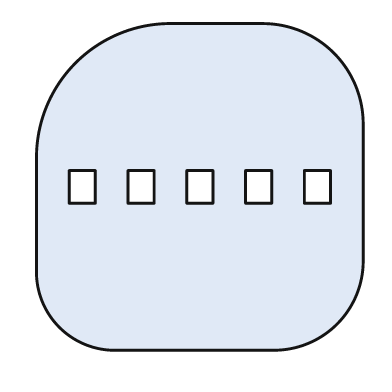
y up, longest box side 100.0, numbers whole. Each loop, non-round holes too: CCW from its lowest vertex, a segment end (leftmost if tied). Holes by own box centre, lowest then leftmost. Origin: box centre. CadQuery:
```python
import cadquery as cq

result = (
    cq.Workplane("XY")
    .moveTo(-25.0, -50.0)
    .lineTo(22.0, -50.0)
    .threePointArc((42.0, -42.0), (50.0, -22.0))
    .lineTo(50.0, 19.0)
    .threePointArc((41.0, 41.0), (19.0, 50.0))
    .lineTo(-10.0, 50.0)
    .threePointArc((-38.0, 38.0), (-50.0, 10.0))
    .lineTo(-50.0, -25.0)
    .threePointArc((-43.0, -43.0), (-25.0, -50.0))
    .close()
    .moveTo(-40.0, -5.0)
    .lineTo(-32.0, -5.0)
    .lineTo(-32.0, 5.0)
    .lineTo(-40.0, 5.0)
    .close()
    .moveTo(-22.0, -5.0)
    .lineTo(-14.0, -5.0)
    .lineTo(-14.0, 5.0)
    .lineTo(-22.0, 5.0)
    .close()
    .moveTo(-4.0, -5.0)
    .lineTo(4.0, -5.0)
    .lineTo(4.0, 5.0)
    .lineTo(-4.0, 5.0)
    .close()
    .moveTo(14.0, -5.0)
    .lineTo(22.0, -5.0)
    .lineTo(22.0, 5.0)
    .lineTo(14.0, 5.0)
    .close()
    .moveTo(32.0, -5.0)
    .lineTo(40.0, -5.0)
    .lineTo(40.0, 5.0)
    .lineTo(32.0, 5.0)
    .close()
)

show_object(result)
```